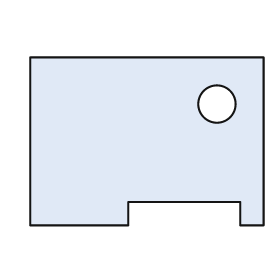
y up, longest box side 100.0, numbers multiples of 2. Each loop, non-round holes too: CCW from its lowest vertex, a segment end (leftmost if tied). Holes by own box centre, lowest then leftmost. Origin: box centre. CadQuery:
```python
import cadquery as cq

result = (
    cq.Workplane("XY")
    .moveTo(-50.0, -36.0)
    .lineTo(-8.0, -36.0)
    .lineTo(-8.0, -26.0)
    .lineTo(40.0, -26.0)
    .lineTo(40.0, -36.0)
    .lineTo(50.0, -36.0)
    .lineTo(50.0, 36.0)
    .lineTo(-50.0, 36.0)
    .close()
    .moveTo(30.0, 16.0)
    .circle(8.0)
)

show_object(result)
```